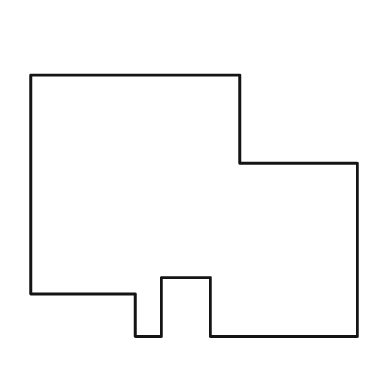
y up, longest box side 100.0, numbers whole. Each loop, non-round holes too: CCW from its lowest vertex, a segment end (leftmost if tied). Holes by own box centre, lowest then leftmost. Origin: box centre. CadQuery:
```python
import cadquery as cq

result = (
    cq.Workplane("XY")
    .moveTo(-18.0, -40.0)
    .lineTo(-10.0, -40.0)
    .lineTo(-10.0, -22.0)
    .lineTo(5.0, -22.0)
    .lineTo(5.0, -40.0)
    .lineTo(50.0, -40.0)
    .lineTo(50.0, 13.0)
    .lineTo(14.0, 13.0)
    .lineTo(14.0, 40.0)
    .lineTo(-50.0, 40.0)
    .lineTo(-50.0, -27.0)
    .lineTo(-18.0, -27.0)
    .close()
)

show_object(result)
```